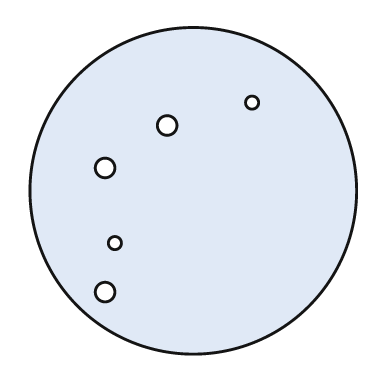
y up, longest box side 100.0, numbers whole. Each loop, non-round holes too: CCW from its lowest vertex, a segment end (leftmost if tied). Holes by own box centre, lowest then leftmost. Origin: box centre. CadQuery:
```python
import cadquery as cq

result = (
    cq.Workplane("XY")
    .moveTo(0.0, 0.0)
    .circle(50.0)
    .moveTo(-27.0, -31.0)
    .circle(3.0)
    .moveTo(-24.0, -16.0)
    .circle(2.0)
    .moveTo(-27.0, 7.0)
    .circle(3.0)
    .moveTo(-8.0, 20.0)
    .circle(3.0)
    .moveTo(18.0, 27.0)
    .circle(2.0)
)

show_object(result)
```